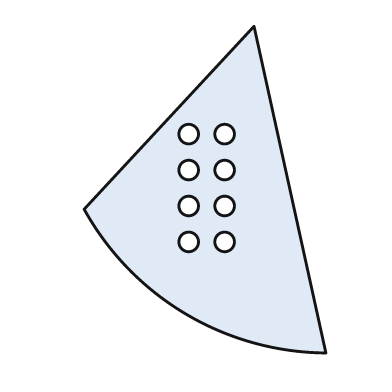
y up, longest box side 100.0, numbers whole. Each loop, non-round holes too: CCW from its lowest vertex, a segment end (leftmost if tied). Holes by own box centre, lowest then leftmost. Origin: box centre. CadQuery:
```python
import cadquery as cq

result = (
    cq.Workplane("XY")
    .moveTo(37.0, -50.0)
    .lineTo(15.0, 50.0)
    .lineTo(-37.0, -6.0)
    .threePointArc((-6.0, -38.0), (37.0, -50.0))
    .close()
    .moveTo(-5.0, -16.0)
    .circle(3.0)
    .moveTo(6.0, -16.0)
    .circle(3.0)
    .moveTo(-5.0, -5.0)
    .circle(3.0)
    .moveTo(6.0, -5.0)
    .circle(3.0)
    .moveTo(-5.0, 6.0)
    .circle(3.0)
    .moveTo(6.0, 6.0)
    .circle(3.0)
    .moveTo(-5.0, 17.0)
    .circle(3.0)
    .moveTo(6.0, 17.0)
    .circle(3.0)
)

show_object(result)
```